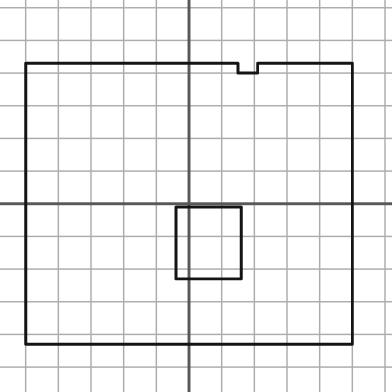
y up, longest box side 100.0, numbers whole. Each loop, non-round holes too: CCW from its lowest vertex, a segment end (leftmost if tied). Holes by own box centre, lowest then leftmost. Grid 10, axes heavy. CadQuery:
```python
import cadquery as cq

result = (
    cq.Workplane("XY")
    .moveTo(-50.0, -43.0)
    .lineTo(50.0, -43.0)
    .lineTo(50.0, 43.0)
    .lineTo(21.0, 43.0)
    .lineTo(21.0, 40.0)
    .lineTo(15.0, 40.0)
    .lineTo(15.0, 43.0)
    .lineTo(-50.0, 43.0)
    .close()
    .moveTo(-4.0, -23.0)
    .lineTo(16.0, -23.0)
    .lineTo(16.0, -1.0)
    .lineTo(-4.0, -1.0)
    .close()
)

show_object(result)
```